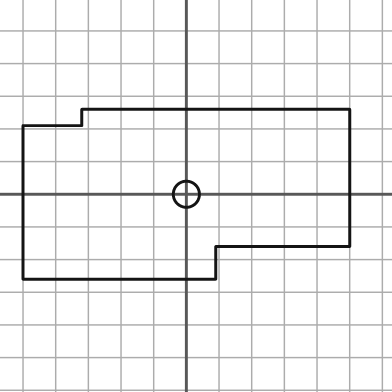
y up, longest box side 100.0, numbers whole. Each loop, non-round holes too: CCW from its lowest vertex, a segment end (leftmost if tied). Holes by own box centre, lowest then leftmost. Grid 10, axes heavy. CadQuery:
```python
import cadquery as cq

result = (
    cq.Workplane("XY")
    .moveTo(-50.0, -26.0)
    .lineTo(9.0, -26.0)
    .lineTo(9.0, -16.0)
    .lineTo(50.0, -16.0)
    .lineTo(50.0, 26.0)
    .lineTo(-32.0, 26.0)
    .lineTo(-32.0, 21.0)
    .lineTo(-50.0, 21.0)
    .close()
    .moveTo(0.0, 0.0)
    .circle(4.0)
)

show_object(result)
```